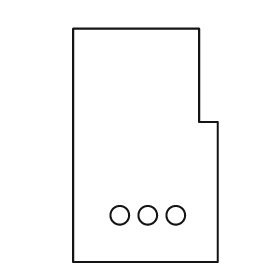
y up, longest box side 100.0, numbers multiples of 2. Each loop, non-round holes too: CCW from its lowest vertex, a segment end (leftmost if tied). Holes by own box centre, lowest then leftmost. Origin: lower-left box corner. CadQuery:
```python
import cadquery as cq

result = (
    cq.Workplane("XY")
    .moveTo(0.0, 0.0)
    .lineTo(62.0, 0.0)
    .lineTo(62.0, 60.0)
    .lineTo(54.0, 60.0)
    .lineTo(54.0, 100.0)
    .lineTo(0.0, 100.0)
    .close()
    .moveTo(20.0, 20.0)
    .circle(4.0)
    .moveTo(32.0, 20.0)
    .circle(4.0)
    .moveTo(44.0, 20.0)
    .circle(4.0)
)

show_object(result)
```